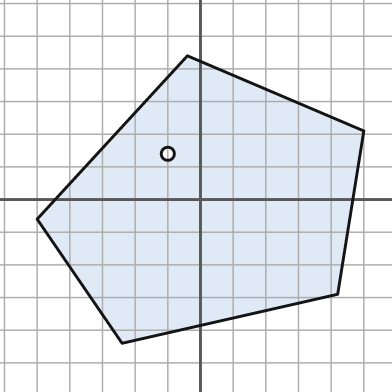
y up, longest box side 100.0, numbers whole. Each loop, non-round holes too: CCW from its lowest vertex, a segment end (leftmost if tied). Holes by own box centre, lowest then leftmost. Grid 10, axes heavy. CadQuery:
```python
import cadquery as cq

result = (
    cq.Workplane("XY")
    .moveTo(-24.0, -44.0)
    .lineTo(42.0, -29.0)
    .lineTo(50.0, 21.0)
    .lineTo(-4.0, 44.0)
    .lineTo(-50.0, -6.0)
    .close()
    .moveTo(-10.0, 14.0)
    .circle(2.0)
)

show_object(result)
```